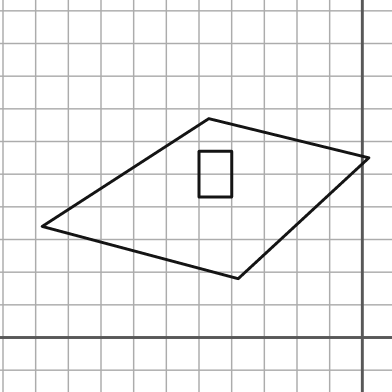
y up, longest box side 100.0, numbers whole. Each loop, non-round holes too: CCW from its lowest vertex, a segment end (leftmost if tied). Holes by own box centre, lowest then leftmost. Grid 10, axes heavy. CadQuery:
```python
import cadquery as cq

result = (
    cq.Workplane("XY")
    .moveTo(-38.0, 18.0)
    .lineTo(2.0, 55.0)
    .lineTo(-47.0, 67.0)
    .lineTo(-98.0, 34.0)
    .close()
    .moveTo(-50.0, 43.0)
    .lineTo(-40.0, 43.0)
    .lineTo(-40.0, 57.0)
    .lineTo(-50.0, 57.0)
    .close()
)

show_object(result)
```